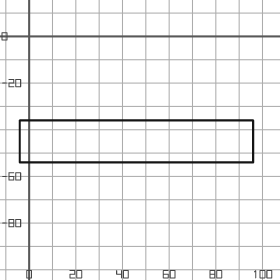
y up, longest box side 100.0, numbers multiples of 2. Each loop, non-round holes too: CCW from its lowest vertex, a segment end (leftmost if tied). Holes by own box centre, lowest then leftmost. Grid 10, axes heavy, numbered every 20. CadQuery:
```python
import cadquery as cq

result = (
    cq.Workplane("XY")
    .moveTo(-4.0, -54.0)
    .lineTo(96.0, -54.0)
    .lineTo(96.0, -36.0)
    .lineTo(-4.0, -36.0)
    .close()
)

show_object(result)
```